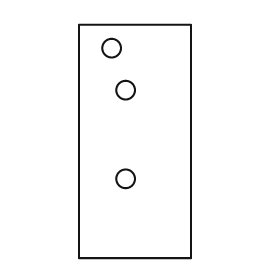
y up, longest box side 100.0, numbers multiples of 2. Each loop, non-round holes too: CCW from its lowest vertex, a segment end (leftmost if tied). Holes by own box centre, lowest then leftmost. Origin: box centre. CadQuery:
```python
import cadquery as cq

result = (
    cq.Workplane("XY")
    .moveTo(-24.0, -50.0)
    .lineTo(24.0, -50.0)
    .lineTo(24.0, 50.0)
    .lineTo(-24.0, 50.0)
    .close()
    .moveTo(-4.0, -16.0)
    .circle(4.0)
    .moveTo(-4.0, 22.0)
    .circle(4.0)
    .moveTo(-10.0, 40.0)
    .circle(4.0)
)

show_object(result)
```